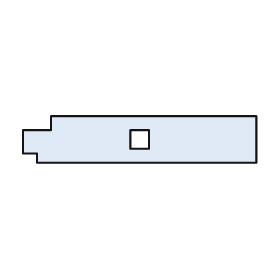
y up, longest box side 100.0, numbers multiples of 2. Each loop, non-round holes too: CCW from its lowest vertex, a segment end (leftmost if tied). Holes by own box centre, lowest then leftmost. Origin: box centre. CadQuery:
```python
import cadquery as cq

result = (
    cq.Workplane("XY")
    .moveTo(-44.0, -10.0)
    .lineTo(50.0, -10.0)
    .lineTo(50.0, 10.0)
    .lineTo(-38.0, 10.0)
    .lineTo(-38.0, 4.0)
    .lineTo(-50.0, 4.0)
    .lineTo(-50.0, -6.0)
    .lineTo(-44.0, -6.0)
    .close()
    .moveTo(-4.0, -4.0)
    .lineTo(4.0, -4.0)
    .lineTo(4.0, 4.0)
    .lineTo(-4.0, 4.0)
    .close()
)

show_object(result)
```